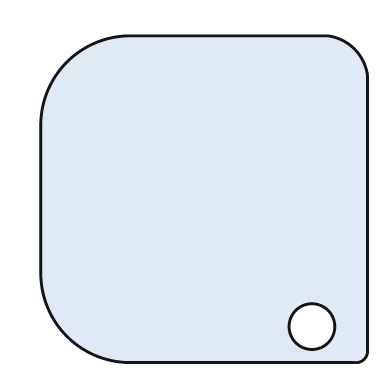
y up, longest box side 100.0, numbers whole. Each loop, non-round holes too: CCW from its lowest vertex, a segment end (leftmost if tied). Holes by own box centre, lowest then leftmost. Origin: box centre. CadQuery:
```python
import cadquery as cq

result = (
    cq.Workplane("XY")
    .moveTo(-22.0, -50.0)
    .lineTo(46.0, -50.0)
    .threePointArc((49.0, -49.0), (50.0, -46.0))
    .lineTo(50.0, 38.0)
    .threePointArc((46.0, 46.0), (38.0, 50.0))
    .lineTo(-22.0, 50.0)
    .threePointArc((-42.0, 42.0), (-50.0, 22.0))
    .lineTo(-50.0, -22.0)
    .threePointArc((-42.0, -42.0), (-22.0, -50.0))
    .close()
    .moveTo(33.0, -39.0)
    .circle(7.0)
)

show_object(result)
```